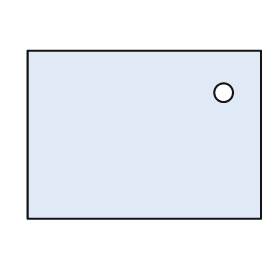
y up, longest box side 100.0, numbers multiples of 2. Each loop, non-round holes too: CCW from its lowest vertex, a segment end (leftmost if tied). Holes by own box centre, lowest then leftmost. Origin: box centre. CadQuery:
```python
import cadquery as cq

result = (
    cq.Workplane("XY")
    .moveTo(-50.0, -36.0)
    .lineTo(50.0, -36.0)
    .lineTo(50.0, 36.0)
    .lineTo(-50.0, 36.0)
    .close()
    .moveTo(34.0, 18.0)
    .circle(4.0)
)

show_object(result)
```